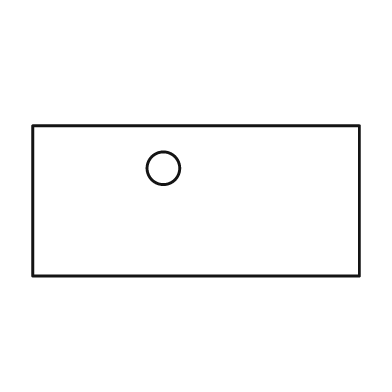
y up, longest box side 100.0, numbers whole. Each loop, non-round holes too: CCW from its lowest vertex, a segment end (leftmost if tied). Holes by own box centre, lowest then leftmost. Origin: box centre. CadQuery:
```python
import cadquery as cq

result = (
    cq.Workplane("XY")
    .moveTo(-50.0, -23.0)
    .lineTo(50.0, -23.0)
    .lineTo(50.0, 23.0)
    .lineTo(-50.0, 23.0)
    .close()
    .moveTo(-10.0, 10.0)
    .circle(5.0)
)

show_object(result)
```